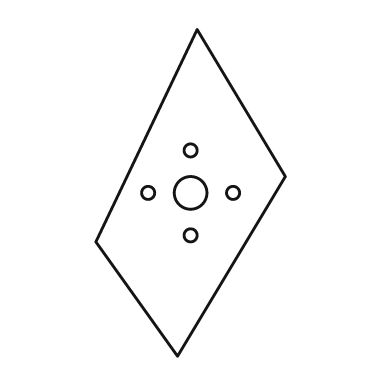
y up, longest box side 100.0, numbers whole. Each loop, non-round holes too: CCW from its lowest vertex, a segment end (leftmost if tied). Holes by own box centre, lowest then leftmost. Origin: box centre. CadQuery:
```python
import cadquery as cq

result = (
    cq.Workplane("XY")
    .moveTo(-4.0, -50.0)
    .lineTo(29.0, 5.0)
    .lineTo(2.0, 50.0)
    .lineTo(-29.0, -15.0)
    .close()
    .moveTo(0.0, -13.0)
    .circle(2.0)
    .moveTo(-13.0, 0.0)
    .circle(2.0)
    .moveTo(0.0, 0.0)
    .circle(5.0)
    .moveTo(13.0, 0.0)
    .circle(2.0)
    .moveTo(0.0, 13.0)
    .circle(2.0)
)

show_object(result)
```